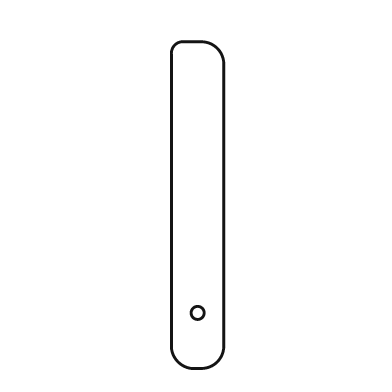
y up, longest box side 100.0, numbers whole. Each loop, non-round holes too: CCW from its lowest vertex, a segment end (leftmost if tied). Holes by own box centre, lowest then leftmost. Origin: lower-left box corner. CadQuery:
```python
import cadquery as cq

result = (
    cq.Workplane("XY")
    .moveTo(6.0, 0.0)
    .lineTo(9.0, 0.0)
    .threePointArc((14.0, 2.0), (16.0, 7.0))
    .lineTo(16.0, 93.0)
    .threePointArc((14.0, 98.0), (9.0, 100.0))
    .lineTo(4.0, 100.0)
    .threePointArc((1.0, 99.0), (0.0, 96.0))
    .lineTo(0.0, 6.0)
    .threePointArc((2.0, 2.0), (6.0, 0.0))
    .close()
    .moveTo(8.0, 17.0)
    .circle(2.0)
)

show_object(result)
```